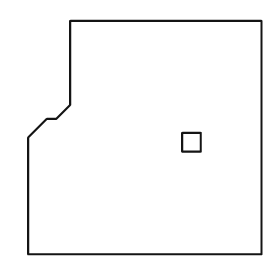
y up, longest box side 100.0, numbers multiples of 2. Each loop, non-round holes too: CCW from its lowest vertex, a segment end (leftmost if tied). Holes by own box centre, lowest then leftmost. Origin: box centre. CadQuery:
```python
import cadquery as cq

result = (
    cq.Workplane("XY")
    .moveTo(-50.0, -50.0)
    .lineTo(50.0, -50.0)
    .lineTo(50.0, 50.0)
    .lineTo(-32.0, 50.0)
    .lineTo(-32.0, 14.0)
    .lineTo(-38.0, 8.0)
    .lineTo(-42.0, 8.0)
    .lineTo(-50.0, 0.0)
    .close()
    .moveTo(16.0, -6.0)
    .lineTo(24.0, -6.0)
    .lineTo(24.0, 2.0)
    .lineTo(16.0, 2.0)
    .close()
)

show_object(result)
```